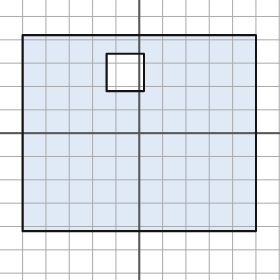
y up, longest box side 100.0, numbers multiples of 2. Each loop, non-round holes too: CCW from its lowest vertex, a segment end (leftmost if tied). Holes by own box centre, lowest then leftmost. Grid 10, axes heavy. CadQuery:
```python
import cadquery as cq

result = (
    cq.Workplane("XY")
    .moveTo(-50.0, -42.0)
    .lineTo(50.0, -42.0)
    .lineTo(50.0, 42.0)
    .lineTo(-50.0, 42.0)
    .close()
    .moveTo(-14.0, 18.0)
    .lineTo(2.0, 18.0)
    .lineTo(2.0, 34.0)
    .lineTo(-14.0, 34.0)
    .close()
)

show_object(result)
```